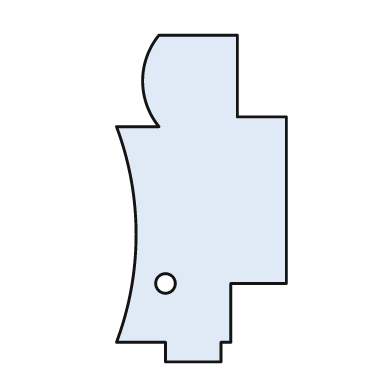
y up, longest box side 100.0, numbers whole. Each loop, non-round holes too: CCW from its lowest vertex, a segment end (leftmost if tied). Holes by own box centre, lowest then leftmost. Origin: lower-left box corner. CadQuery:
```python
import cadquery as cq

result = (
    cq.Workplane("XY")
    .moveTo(15.0, 0.0)
    .lineTo(32.0, 0.0)
    .lineTo(32.0, 6.0)
    .lineTo(35.0, 6.0)
    .lineTo(35.0, 24.0)
    .lineTo(52.0, 24.0)
    .lineTo(52.0, 75.0)
    .lineTo(37.0, 75.0)
    .lineTo(37.0, 100.0)
    .lineTo(13.0, 100.0)
    .threePointArc((8.0, 86.0), (13.0, 72.0))
    .lineTo(0.0, 72.0)
    .threePointArc((6.0, 39.0), (0.0, 6.0))
    .lineTo(15.0, 6.0)
    .close()
    .moveTo(15.0, 24.0)
    .circle(3.0)
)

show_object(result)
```